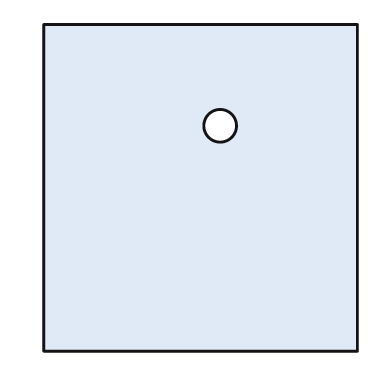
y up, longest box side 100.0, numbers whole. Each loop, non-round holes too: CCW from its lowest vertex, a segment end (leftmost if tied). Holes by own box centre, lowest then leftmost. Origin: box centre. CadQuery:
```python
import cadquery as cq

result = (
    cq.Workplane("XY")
    .moveTo(-48.0, -50.0)
    .lineTo(48.0, -50.0)
    .lineTo(48.0, 50.0)
    .lineTo(-48.0, 50.0)
    .close()
    .moveTo(6.0, 19.0)
    .circle(5.0)
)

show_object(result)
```